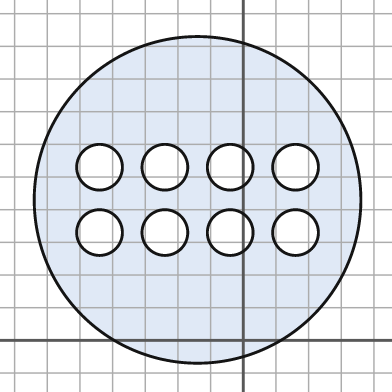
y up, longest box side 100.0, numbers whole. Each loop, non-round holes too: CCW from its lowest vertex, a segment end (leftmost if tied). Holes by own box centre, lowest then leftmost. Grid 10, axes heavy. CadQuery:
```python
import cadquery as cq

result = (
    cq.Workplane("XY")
    .moveTo(-14.0, 43.0)
    .circle(50.0)
    .moveTo(-44.0, 33.0)
    .circle(7.0)
    .moveTo(-24.0, 33.0)
    .circle(7.0)
    .moveTo(-4.0, 33.0)
    .circle(7.0)
    .moveTo(16.0, 33.0)
    .circle(7.0)
    .moveTo(-44.0, 53.0)
    .circle(7.0)
    .moveTo(-24.0, 53.0)
    .circle(7.0)
    .moveTo(-4.0, 53.0)
    .circle(7.0)
    .moveTo(16.0, 53.0)
    .circle(7.0)
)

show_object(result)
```